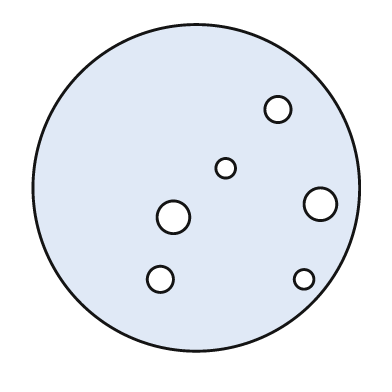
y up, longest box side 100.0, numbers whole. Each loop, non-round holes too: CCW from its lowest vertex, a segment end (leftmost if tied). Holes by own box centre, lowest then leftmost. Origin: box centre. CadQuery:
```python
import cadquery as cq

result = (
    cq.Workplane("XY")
    .moveTo(0.0, 0.0)
    .circle(50.0)
    .moveTo(-11.0, -28.0)
    .circle(4.0)
    .moveTo(33.0, -28.0)
    .circle(3.0)
    .moveTo(-7.0, -9.0)
    .circle(5.0)
    .moveTo(38.0, -5.0)
    .circle(5.0)
    .moveTo(9.0, 6.0)
    .circle(3.0)
    .moveTo(25.0, 24.0)
    .circle(4.0)
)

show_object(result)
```